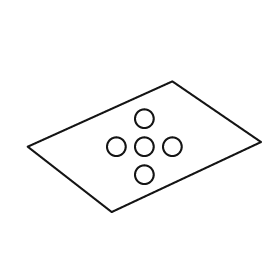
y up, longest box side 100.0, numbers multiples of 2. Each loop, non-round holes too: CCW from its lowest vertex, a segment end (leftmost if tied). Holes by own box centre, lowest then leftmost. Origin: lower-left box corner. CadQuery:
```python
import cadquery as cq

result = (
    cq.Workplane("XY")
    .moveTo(36.0, 0.0)
    .lineTo(100.0, 30.0)
    .lineTo(62.0, 56.0)
    .lineTo(0.0, 28.0)
    .close()
    .moveTo(50.0, 16.0)
    .circle(4.0)
    .moveTo(38.0, 28.0)
    .circle(4.0)
    .moveTo(50.0, 28.0)
    .circle(4.0)
    .moveTo(62.0, 28.0)
    .circle(4.0)
    .moveTo(50.0, 40.0)
    .circle(4.0)
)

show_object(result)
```